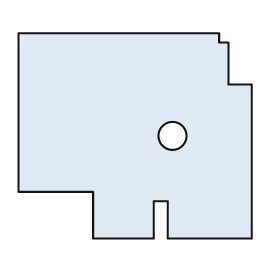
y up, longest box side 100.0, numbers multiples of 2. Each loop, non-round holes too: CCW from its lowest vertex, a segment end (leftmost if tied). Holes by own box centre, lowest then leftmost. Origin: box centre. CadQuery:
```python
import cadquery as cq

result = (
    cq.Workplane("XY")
    .moveTo(-18.0, -44.0)
    .lineTo(8.0, -44.0)
    .lineTo(8.0, -28.0)
    .lineTo(14.0, -28.0)
    .lineTo(14.0, -44.0)
    .lineTo(50.0, -44.0)
    .lineTo(50.0, 22.0)
    .lineTo(40.0, 22.0)
    .lineTo(40.0, 40.0)
    .lineTo(36.0, 40.0)
    .lineTo(36.0, 44.0)
    .lineTo(-50.0, 44.0)
    .lineTo(-50.0, -24.0)
    .lineTo(-18.0, -24.0)
    .close()
    .moveTo(16.0, 0.0)
    .circle(6.0)
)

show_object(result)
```